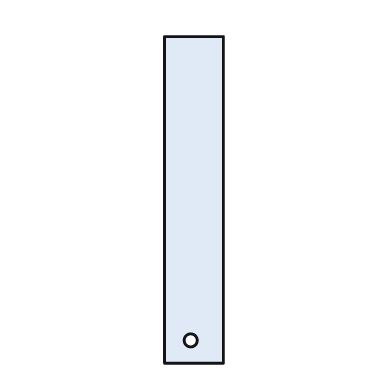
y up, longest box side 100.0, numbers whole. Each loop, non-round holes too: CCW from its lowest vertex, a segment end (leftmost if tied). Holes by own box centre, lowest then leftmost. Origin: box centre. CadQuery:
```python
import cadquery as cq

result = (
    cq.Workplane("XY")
    .moveTo(-9.0, -50.0)
    .lineTo(9.0, -50.0)
    .lineTo(9.0, 50.0)
    .lineTo(-9.0, 50.0)
    .close()
    .moveTo(-1.0, -43.0)
    .circle(2.0)
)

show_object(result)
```